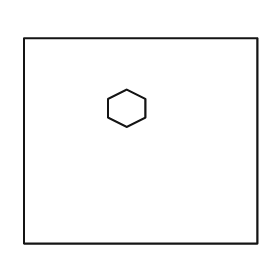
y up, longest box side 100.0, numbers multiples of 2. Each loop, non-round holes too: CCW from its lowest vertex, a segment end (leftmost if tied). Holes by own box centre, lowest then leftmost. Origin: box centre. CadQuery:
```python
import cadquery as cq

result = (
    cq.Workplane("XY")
    .moveTo(-50.0, -44.0)
    .lineTo(50.0, -44.0)
    .lineTo(50.0, 44.0)
    .lineTo(-50.0, 44.0)
    .close()
    .moveTo(-6.0, 6.0)
    .lineTo(2.0, 10.0)
    .lineTo(2.0, 18.0)
    .lineTo(-6.0, 22.0)
    .lineTo(-14.0, 18.0)
    .lineTo(-14.0, 10.0)
    .close()
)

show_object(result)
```